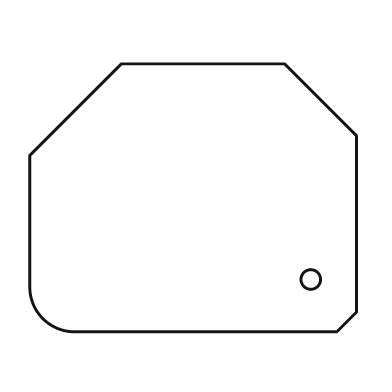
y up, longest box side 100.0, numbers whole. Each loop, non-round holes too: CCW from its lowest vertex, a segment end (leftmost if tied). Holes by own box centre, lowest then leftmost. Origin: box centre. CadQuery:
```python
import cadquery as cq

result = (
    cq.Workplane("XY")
    .moveTo(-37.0, -41.0)
    .lineTo(44.0, -41.0)
    .lineTo(50.0, -35.0)
    .lineTo(50.0, 19.0)
    .lineTo(28.0, 41.0)
    .lineTo(-22.0, 41.0)
    .lineTo(-50.0, 13.0)
    .lineTo(-50.0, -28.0)
    .threePointArc((-46.0, -37.0), (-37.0, -41.0))
    .close()
    .moveTo(36.0, -25.0)
    .circle(3.0)
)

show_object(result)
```